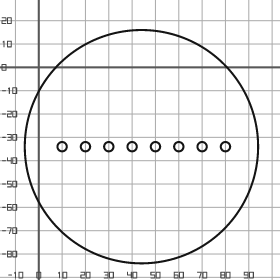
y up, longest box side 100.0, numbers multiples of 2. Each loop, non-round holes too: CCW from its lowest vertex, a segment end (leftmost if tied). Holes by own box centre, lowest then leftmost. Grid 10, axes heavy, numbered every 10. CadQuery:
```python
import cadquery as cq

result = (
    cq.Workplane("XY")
    .moveTo(44.0, -34.0)
    .circle(50.0)
    .moveTo(10.0, -34.0)
    .circle(2.0)
    .moveTo(20.0, -34.0)
    .circle(2.0)
    .moveTo(30.0, -34.0)
    .circle(2.0)
    .moveTo(40.0, -34.0)
    .circle(2.0)
    .moveTo(50.0, -34.0)
    .circle(2.0)
    .moveTo(60.0, -34.0)
    .circle(2.0)
    .moveTo(70.0, -34.0)
    .circle(2.0)
    .moveTo(80.0, -34.0)
    .circle(2.0)
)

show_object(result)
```